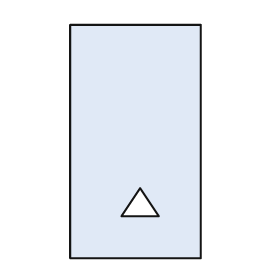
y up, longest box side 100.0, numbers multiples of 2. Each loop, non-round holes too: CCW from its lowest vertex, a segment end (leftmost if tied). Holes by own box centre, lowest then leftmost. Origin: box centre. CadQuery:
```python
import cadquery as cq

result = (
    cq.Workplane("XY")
    .moveTo(-28.0, -50.0)
    .lineTo(28.0, -50.0)
    .lineTo(28.0, 50.0)
    .lineTo(-28.0, 50.0)
    .close()
    .moveTo(-6.0, -32.0)
    .lineTo(10.0, -32.0)
    .lineTo(2.0, -20.0)
    .close()
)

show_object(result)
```